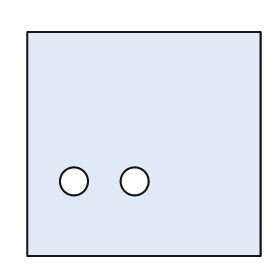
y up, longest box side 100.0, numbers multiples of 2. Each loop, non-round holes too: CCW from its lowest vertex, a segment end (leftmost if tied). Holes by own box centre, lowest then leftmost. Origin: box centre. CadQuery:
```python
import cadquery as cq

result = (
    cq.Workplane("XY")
    .moveTo(-50.0, -48.0)
    .lineTo(50.0, -48.0)
    .lineTo(50.0, 48.0)
    .lineTo(-50.0, 48.0)
    .close()
    .moveTo(-30.0, -16.0)
    .circle(6.0)
    .moveTo(-4.0, -16.0)
    .circle(6.0)
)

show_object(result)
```